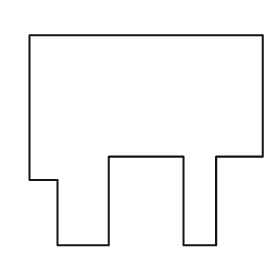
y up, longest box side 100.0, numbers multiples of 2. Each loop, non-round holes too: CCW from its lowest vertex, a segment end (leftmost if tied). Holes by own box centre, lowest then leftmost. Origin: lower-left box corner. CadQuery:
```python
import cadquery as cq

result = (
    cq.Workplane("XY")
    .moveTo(12.0, 0.0)
    .lineTo(34.0, 0.0)
    .lineTo(34.0, 38.0)
    .lineTo(66.0, 38.0)
    .lineTo(66.0, 0.0)
    .lineTo(80.0, 0.0)
    .lineTo(80.0, 38.0)
    .lineTo(100.0, 38.0)
    .lineTo(100.0, 90.0)
    .lineTo(0.0, 90.0)
    .lineTo(0.0, 28.0)
    .lineTo(12.0, 28.0)
    .close()
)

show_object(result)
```